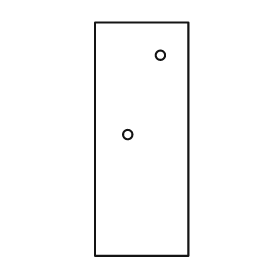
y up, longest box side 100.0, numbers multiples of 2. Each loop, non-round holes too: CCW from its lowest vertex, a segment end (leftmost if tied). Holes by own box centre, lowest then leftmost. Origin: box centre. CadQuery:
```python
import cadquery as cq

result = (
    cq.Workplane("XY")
    .moveTo(-20.0, -50.0)
    .lineTo(20.0, -50.0)
    .lineTo(20.0, 50.0)
    .lineTo(-20.0, 50.0)
    .close()
    .moveTo(-6.0, 2.0)
    .circle(2.0)
    .moveTo(8.0, 36.0)
    .circle(2.0)
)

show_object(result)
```